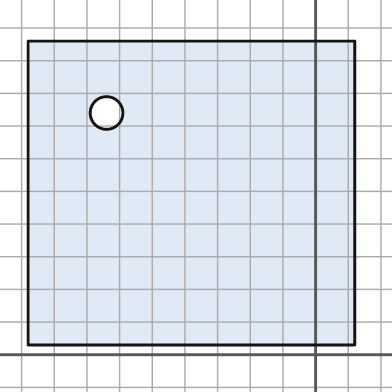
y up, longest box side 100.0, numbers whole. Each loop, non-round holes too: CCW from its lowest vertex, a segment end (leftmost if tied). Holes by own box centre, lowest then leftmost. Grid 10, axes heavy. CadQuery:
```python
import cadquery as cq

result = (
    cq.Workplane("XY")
    .moveTo(-88.0, 3.0)
    .lineTo(12.0, 3.0)
    .lineTo(12.0, 96.0)
    .lineTo(-88.0, 96.0)
    .close()
    .moveTo(-64.0, 74.0)
    .circle(5.0)
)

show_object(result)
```